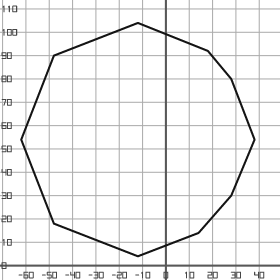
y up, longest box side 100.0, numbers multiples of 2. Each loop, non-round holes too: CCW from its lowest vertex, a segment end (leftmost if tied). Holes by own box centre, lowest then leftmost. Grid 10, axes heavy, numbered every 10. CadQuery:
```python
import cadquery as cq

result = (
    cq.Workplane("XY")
    .moveTo(-12.0, 4.0)
    .lineTo(14.0, 14.0)
    .lineTo(28.0, 30.0)
    .lineTo(38.0, 54.0)
    .lineTo(28.0, 80.0)
    .lineTo(18.0, 92.0)
    .lineTo(-12.0, 104.0)
    .lineTo(-48.0, 90.0)
    .lineTo(-62.0, 54.0)
    .lineTo(-48.0, 18.0)
    .close()
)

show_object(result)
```